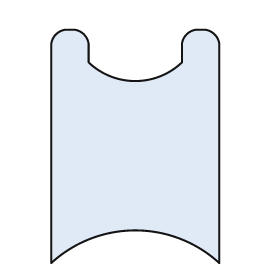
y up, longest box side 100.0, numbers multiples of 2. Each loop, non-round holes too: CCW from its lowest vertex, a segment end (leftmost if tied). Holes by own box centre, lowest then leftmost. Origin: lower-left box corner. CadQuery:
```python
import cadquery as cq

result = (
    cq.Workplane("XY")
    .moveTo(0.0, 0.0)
    .threePointArc((36.0, 14.0), (72.0, 0.0))
    .lineTo(72.0, 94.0)
    .threePointArc((70.0, 98.0), (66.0, 100.0))
    .lineTo(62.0, 100.0)
    .threePointArc((58.0, 98.0), (56.0, 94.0))
    .lineTo(56.0, 86.0)
    .threePointArc((36.0, 78.0), (16.0, 86.0))
    .lineTo(16.0, 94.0)
    .threePointArc((14.0, 98.0), (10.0, 100.0))
    .lineTo(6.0, 100.0)
    .threePointArc((2.0, 98.0), (0.0, 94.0))
    .close()
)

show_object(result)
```